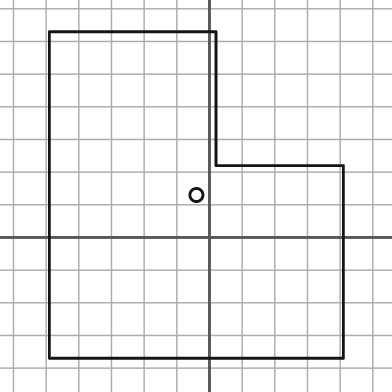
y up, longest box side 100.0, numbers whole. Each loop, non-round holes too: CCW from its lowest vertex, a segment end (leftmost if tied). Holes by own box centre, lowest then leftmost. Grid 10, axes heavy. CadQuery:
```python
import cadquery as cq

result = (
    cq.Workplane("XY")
    .moveTo(-49.0, -37.0)
    .lineTo(41.0, -37.0)
    .lineTo(41.0, 22.0)
    .lineTo(2.0, 22.0)
    .lineTo(2.0, 63.0)
    .lineTo(-49.0, 63.0)
    .close()
    .moveTo(-4.0, 13.0)
    .circle(2.0)
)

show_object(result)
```